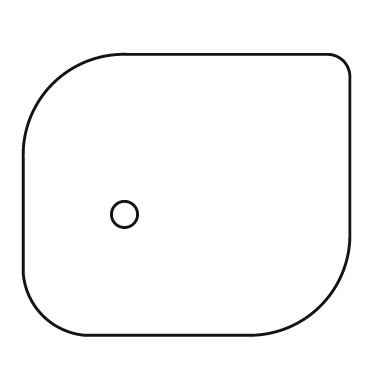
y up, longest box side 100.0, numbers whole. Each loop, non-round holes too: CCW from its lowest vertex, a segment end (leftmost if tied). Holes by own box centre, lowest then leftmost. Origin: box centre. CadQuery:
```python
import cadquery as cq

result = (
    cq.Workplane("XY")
    .moveTo(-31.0, -43.0)
    .lineTo(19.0, -43.0)
    .threePointArc((41.0, -34.0), (50.0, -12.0))
    .lineTo(50.0, 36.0)
    .threePointArc((48.0, 41.0), (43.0, 43.0))
    .lineTo(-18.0, 43.0)
    .threePointArc((-41.0, 34.0), (-50.0, 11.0))
    .lineTo(-50.0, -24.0)
    .threePointArc((-44.0, -37.0), (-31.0, -43.0))
    .close()
    .moveTo(-19.0, -6.0)
    .circle(4.0)
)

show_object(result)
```